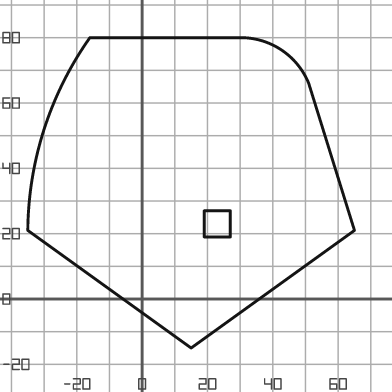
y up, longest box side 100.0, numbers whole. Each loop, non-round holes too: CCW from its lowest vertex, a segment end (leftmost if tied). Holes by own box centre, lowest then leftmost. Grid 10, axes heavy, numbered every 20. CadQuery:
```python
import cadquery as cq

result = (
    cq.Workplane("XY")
    .moveTo(15.0, -15.0)
    .lineTo(65.0, 21.0)
    .lineTo(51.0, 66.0)
    .threePointArc((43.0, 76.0), (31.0, 80.0))
    .lineTo(-16.0, 80.0)
    .threePointArc((-30.0, 52.0), (-35.0, 21.0))
    .close()
    .moveTo(19.0, 19.0)
    .lineTo(27.0, 19.0)
    .lineTo(27.0, 27.0)
    .lineTo(19.0, 27.0)
    .close()
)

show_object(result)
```